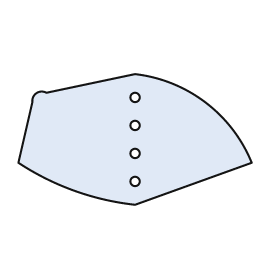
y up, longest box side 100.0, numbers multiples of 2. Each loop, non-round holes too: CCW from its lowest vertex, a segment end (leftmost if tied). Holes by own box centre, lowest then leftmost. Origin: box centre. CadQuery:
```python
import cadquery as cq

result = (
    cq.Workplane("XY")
    .moveTo(0.0, -28.0)
    .lineTo(50.0, -10.0)
    .threePointArc((30.0, 16.0), (0.0, 28.0))
    .lineTo(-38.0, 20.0)
    .threePointArc((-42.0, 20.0), (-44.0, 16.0))
    .lineTo(-50.0, -10.0)
    .threePointArc((-26.0, -22.0), (0.0, -28.0))
    .close()
    .moveTo(0.0, -18.0)
    .circle(2.0)
    .moveTo(0.0, -6.0)
    .circle(2.0)
    .moveTo(0.0, 6.0)
    .circle(2.0)
    .moveTo(0.0, 18.0)
    .circle(2.0)
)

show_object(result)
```